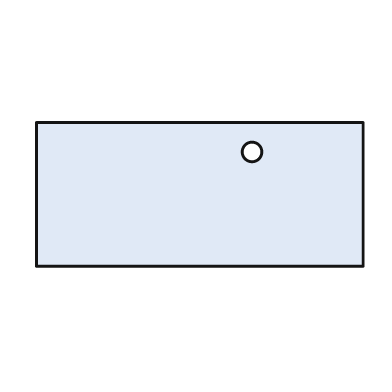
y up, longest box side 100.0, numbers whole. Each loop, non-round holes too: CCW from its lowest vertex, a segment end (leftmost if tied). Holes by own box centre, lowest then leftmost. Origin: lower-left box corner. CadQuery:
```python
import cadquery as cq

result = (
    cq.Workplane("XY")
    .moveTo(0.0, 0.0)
    .lineTo(100.0, 0.0)
    .lineTo(100.0, 44.0)
    .lineTo(0.0, 44.0)
    .close()
    .moveTo(66.0, 35.0)
    .circle(3.0)
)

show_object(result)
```